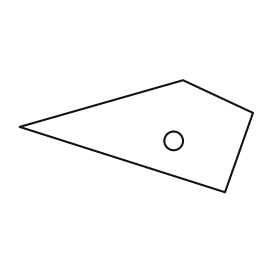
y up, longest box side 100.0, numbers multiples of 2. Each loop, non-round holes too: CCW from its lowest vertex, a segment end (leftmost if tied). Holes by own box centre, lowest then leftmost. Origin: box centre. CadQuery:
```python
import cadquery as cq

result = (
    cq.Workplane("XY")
    .moveTo(38.0, -24.0)
    .lineTo(50.0, 10.0)
    .lineTo(20.0, 24.0)
    .lineTo(-50.0, 4.0)
    .close()
    .moveTo(16.0, -2.0)
    .circle(4.0)
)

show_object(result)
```